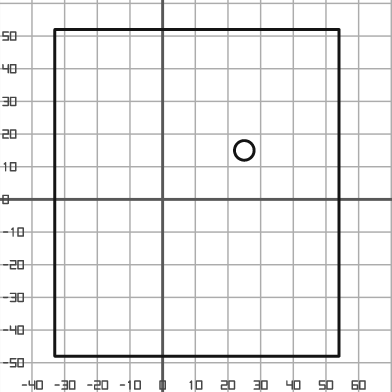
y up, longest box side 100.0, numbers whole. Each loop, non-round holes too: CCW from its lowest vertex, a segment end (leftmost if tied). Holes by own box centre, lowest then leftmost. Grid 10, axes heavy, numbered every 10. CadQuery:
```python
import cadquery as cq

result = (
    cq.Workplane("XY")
    .moveTo(-33.0, -48.0)
    .lineTo(54.0, -48.0)
    .lineTo(54.0, 52.0)
    .lineTo(-33.0, 52.0)
    .close()
    .moveTo(25.0, 15.0)
    .circle(3.0)
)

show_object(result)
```